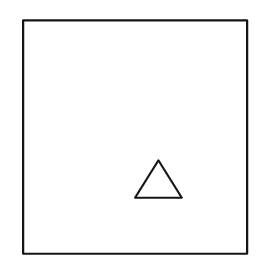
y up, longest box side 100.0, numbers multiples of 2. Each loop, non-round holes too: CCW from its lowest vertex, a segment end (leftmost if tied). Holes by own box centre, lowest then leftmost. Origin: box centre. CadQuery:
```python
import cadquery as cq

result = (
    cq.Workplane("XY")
    .moveTo(-48.0, -50.0)
    .lineTo(48.0, -50.0)
    .lineTo(48.0, 50.0)
    .lineTo(-48.0, 50.0)
    .close()
    .moveTo(0.0, -26.0)
    .lineTo(20.0, -26.0)
    .lineTo(10.0, -10.0)
    .close()
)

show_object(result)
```